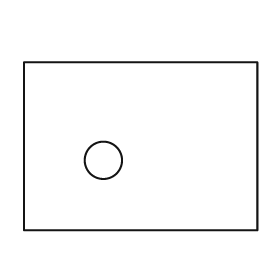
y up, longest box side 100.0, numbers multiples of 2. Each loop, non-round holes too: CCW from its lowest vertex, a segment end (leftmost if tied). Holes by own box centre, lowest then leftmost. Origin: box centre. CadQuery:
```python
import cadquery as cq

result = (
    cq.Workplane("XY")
    .moveTo(-50.0, -36.0)
    .lineTo(50.0, -36.0)
    .lineTo(50.0, 36.0)
    .lineTo(-50.0, 36.0)
    .close()
    .moveTo(-16.0, -6.0)
    .circle(8.0)
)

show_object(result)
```